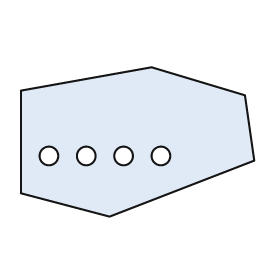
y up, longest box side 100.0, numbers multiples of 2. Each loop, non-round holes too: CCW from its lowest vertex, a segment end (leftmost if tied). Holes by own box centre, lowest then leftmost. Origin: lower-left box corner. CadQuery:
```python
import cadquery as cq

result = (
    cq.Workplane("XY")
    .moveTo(38.0, 0.0)
    .lineTo(100.0, 24.0)
    .lineTo(96.0, 52.0)
    .lineTo(56.0, 64.0)
    .lineTo(0.0, 54.0)
    .lineTo(0.0, 10.0)
    .close()
    .moveTo(12.0, 26.0)
    .circle(4.0)
    .moveTo(28.0, 26.0)
    .circle(4.0)
    .moveTo(44.0, 26.0)
    .circle(4.0)
    .moveTo(60.0, 26.0)
    .circle(4.0)
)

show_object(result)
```